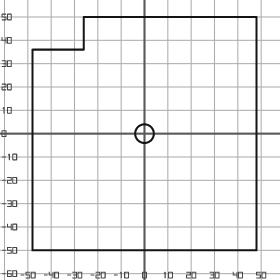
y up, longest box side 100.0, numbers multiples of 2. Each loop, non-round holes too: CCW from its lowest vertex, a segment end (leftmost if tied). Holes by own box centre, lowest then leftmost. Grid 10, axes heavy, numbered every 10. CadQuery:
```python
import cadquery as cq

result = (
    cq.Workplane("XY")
    .moveTo(-48.0, -50.0)
    .lineTo(48.0, -50.0)
    .lineTo(48.0, 50.0)
    .lineTo(-26.0, 50.0)
    .lineTo(-26.0, 36.0)
    .lineTo(-48.0, 36.0)
    .close()
    .moveTo(0.0, 0.0)
    .circle(4.0)
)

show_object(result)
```